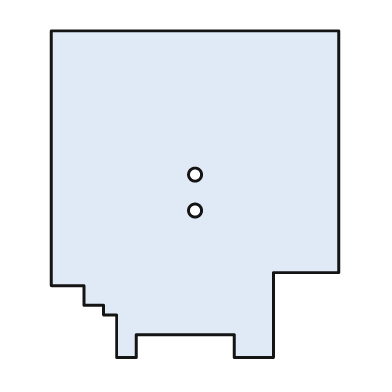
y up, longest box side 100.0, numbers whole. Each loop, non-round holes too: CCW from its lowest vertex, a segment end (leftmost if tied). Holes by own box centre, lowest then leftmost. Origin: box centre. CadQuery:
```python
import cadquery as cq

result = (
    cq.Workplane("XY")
    .moveTo(-24.0, -50.0)
    .lineTo(-18.0, -50.0)
    .lineTo(-18.0, -43.0)
    .lineTo(12.0, -43.0)
    .lineTo(12.0, -50.0)
    .lineTo(24.0, -50.0)
    .lineTo(24.0, -24.0)
    .lineTo(44.0, -24.0)
    .lineTo(44.0, 50.0)
    .lineTo(-44.0, 50.0)
    .lineTo(-44.0, -28.0)
    .lineTo(-34.0, -28.0)
    .lineTo(-34.0, -34.0)
    .lineTo(-28.0, -34.0)
    .lineTo(-28.0, -37.0)
    .lineTo(-24.0, -37.0)
    .close()
    .moveTo(0.0, -5.0)
    .circle(2.0)
    .moveTo(0.0, 6.0)
    .circle(2.0)
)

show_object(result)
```